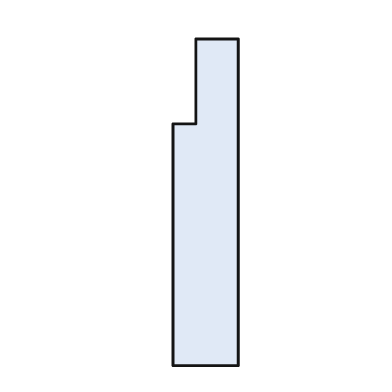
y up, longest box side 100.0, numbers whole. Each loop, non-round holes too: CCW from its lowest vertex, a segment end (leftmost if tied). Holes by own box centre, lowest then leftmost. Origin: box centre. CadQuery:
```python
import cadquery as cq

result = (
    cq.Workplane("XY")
    .moveTo(-10.0, -50.0)
    .lineTo(10.0, -50.0)
    .lineTo(10.0, 50.0)
    .lineTo(-3.0, 50.0)
    .lineTo(-3.0, 24.0)
    .lineTo(-10.0, 24.0)
    .close()
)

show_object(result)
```